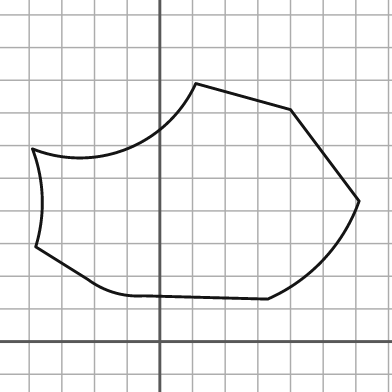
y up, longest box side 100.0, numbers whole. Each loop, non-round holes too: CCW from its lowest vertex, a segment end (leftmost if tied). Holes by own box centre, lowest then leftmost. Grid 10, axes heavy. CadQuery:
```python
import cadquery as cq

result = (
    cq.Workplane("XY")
    .moveTo(33.0, 13.0)
    .threePointArc((50.0, 25.0), (61.0, 43.0))
    .lineTo(40.0, 71.0)
    .lineTo(11.0, 79.0)
    .threePointArc((-10.0, 59.0), (-39.0, 59.0))
    .threePointArc((-36.0, 44.0), (-38.0, 29.0))
    .lineTo(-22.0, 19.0)
    .threePointArc((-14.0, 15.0), (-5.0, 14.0))
    .close()
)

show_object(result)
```